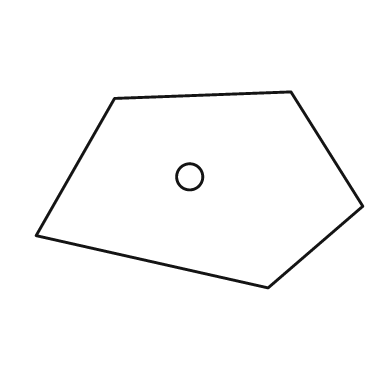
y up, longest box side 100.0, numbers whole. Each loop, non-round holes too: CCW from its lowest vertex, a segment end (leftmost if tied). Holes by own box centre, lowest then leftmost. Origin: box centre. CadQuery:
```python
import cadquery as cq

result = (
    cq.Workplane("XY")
    .moveTo(21.0, -30.0)
    .lineTo(50.0, -5.0)
    .lineTo(28.0, 30.0)
    .lineTo(-26.0, 28.0)
    .lineTo(-50.0, -14.0)
    .close()
    .moveTo(-3.0, 4.0)
    .circle(4.0)
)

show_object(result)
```